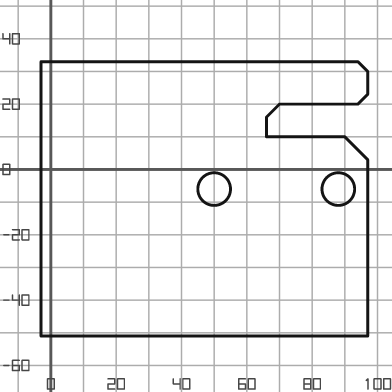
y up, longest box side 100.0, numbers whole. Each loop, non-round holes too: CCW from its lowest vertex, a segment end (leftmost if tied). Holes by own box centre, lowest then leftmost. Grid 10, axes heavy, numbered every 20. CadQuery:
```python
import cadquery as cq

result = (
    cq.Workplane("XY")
    .moveTo(-3.0, -51.0)
    .lineTo(97.0, -51.0)
    .lineTo(97.0, 3.0)
    .lineTo(90.0, 10.0)
    .lineTo(66.0, 10.0)
    .lineTo(66.0, 16.0)
    .lineTo(70.0, 20.0)
    .lineTo(94.0, 20.0)
    .lineTo(97.0, 23.0)
    .lineTo(97.0, 30.0)
    .lineTo(94.0, 33.0)
    .lineTo(-3.0, 33.0)
    .close()
    .moveTo(50.0, -6.0)
    .circle(5.0)
    .moveTo(88.0, -6.0)
    .circle(5.0)
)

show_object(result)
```